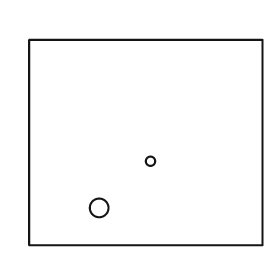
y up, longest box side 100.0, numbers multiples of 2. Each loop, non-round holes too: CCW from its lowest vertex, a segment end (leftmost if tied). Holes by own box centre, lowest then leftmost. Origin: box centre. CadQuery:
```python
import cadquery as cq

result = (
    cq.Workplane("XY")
    .moveTo(-50.0, -44.0)
    .lineTo(50.0, -44.0)
    .lineTo(50.0, 44.0)
    .lineTo(-50.0, 44.0)
    .close()
    .moveTo(-20.0, -28.0)
    .circle(4.0)
    .moveTo(2.0, -8.0)
    .circle(2.0)
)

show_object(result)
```